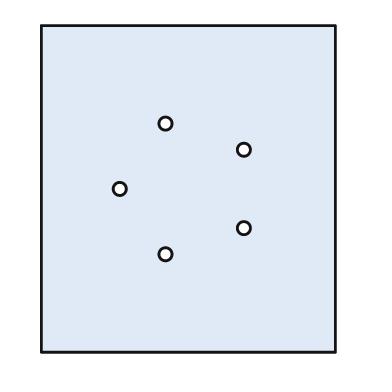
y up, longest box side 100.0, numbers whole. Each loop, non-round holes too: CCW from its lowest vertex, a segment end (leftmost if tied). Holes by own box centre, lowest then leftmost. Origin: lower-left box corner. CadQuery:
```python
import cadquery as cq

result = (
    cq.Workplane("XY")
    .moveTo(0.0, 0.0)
    .lineTo(90.0, 0.0)
    .lineTo(90.0, 100.0)
    .lineTo(0.0, 100.0)
    .close()
    .moveTo(38.0, 30.0)
    .circle(2.0)
    .moveTo(62.0, 38.0)
    .circle(2.0)
    .moveTo(24.0, 50.0)
    .circle(2.0)
    .moveTo(62.0, 62.0)
    .circle(2.0)
    .moveTo(38.0, 70.0)
    .circle(2.0)
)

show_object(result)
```